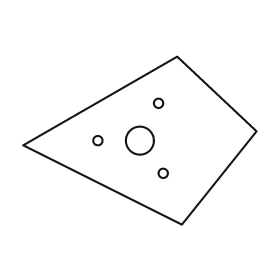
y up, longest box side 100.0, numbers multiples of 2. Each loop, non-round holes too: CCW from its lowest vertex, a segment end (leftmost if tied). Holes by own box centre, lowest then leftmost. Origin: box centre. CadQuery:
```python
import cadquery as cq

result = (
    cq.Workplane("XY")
    .moveTo(18.0, -36.0)
    .lineTo(50.0, 4.0)
    .lineTo(16.0, 36.0)
    .lineTo(-50.0, -2.0)
    .close()
    .moveTo(10.0, -14.0)
    .circle(2.0)
    .moveTo(-18.0, 0.0)
    .circle(2.0)
    .moveTo(0.0, 0.0)
    .circle(6.0)
    .moveTo(8.0, 16.0)
    .circle(2.0)
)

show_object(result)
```